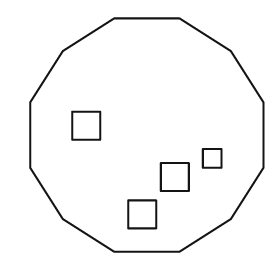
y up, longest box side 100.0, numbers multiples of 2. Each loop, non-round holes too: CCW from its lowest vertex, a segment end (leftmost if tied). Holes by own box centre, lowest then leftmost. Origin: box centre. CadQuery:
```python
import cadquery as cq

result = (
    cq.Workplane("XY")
    .moveTo(-14.0, -50.0)
    .lineTo(14.0, -50.0)
    .lineTo(36.0, -36.0)
    .lineTo(50.0, -14.0)
    .lineTo(50.0, 14.0)
    .lineTo(36.0, 36.0)
    .lineTo(14.0, 50.0)
    .lineTo(-14.0, 50.0)
    .lineTo(-36.0, 36.0)
    .lineTo(-50.0, 14.0)
    .lineTo(-50.0, -14.0)
    .lineTo(-36.0, -36.0)
    .close()
    .moveTo(-8.0, -40.0)
    .lineTo(4.0, -40.0)
    .lineTo(4.0, -28.0)
    .lineTo(-8.0, -28.0)
    .close()
    .moveTo(6.0, -24.0)
    .lineTo(18.0, -24.0)
    .lineTo(18.0, -12.0)
    .lineTo(6.0, -12.0)
    .close()
    .moveTo(24.0, -14.0)
    .lineTo(32.0, -14.0)
    .lineTo(32.0, -6.0)
    .lineTo(24.0, -6.0)
    .close()
    .moveTo(-32.0, -2.0)
    .lineTo(-20.0, -2.0)
    .lineTo(-20.0, 10.0)
    .lineTo(-32.0, 10.0)
    .close()
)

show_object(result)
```